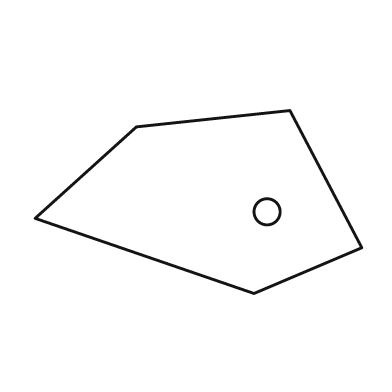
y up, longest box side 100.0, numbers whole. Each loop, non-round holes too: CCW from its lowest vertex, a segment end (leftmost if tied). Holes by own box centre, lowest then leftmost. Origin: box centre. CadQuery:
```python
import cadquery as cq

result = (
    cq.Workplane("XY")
    .moveTo(17.0, -28.0)
    .lineTo(50.0, -14.0)
    .lineTo(28.0, 28.0)
    .lineTo(-19.0, 23.0)
    .lineTo(-50.0, -5.0)
    .close()
    .moveTo(21.0, -3.0)
    .circle(4.0)
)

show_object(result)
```